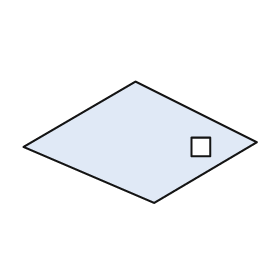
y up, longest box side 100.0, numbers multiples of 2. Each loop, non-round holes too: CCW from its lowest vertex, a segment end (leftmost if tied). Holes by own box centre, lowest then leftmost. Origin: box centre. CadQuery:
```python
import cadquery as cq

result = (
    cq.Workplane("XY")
    .moveTo(6.0, -26.0)
    .lineTo(50.0, 0.0)
    .lineTo(-2.0, 26.0)
    .lineTo(-50.0, -2.0)
    .close()
    .moveTo(22.0, -6.0)
    .lineTo(30.0, -6.0)
    .lineTo(30.0, 2.0)
    .lineTo(22.0, 2.0)
    .close()
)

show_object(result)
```